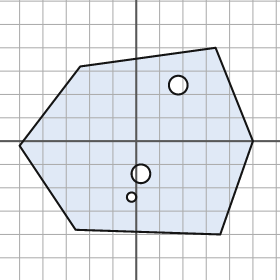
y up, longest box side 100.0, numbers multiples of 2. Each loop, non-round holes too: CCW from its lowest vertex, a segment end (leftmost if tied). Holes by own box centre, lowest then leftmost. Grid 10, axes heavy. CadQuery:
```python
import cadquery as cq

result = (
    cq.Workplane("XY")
    .moveTo(36.0, -40.0)
    .lineTo(50.0, 0.0)
    .lineTo(34.0, 40.0)
    .lineTo(-24.0, 32.0)
    .lineTo(-50.0, -2.0)
    .lineTo(-26.0, -38.0)
    .close()
    .moveTo(-2.0, -24.0)
    .circle(2.0)
    .moveTo(2.0, -14.0)
    .circle(4.0)
    .moveTo(18.0, 24.0)
    .circle(4.0)
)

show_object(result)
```